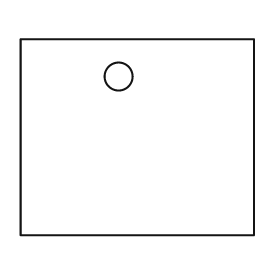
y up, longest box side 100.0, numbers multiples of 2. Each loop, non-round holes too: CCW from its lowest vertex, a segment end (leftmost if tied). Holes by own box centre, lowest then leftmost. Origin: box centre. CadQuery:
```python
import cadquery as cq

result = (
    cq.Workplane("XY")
    .moveTo(-50.0, -42.0)
    .lineTo(50.0, -42.0)
    .lineTo(50.0, 42.0)
    .lineTo(-50.0, 42.0)
    .close()
    .moveTo(-8.0, 26.0)
    .circle(6.0)
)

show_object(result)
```